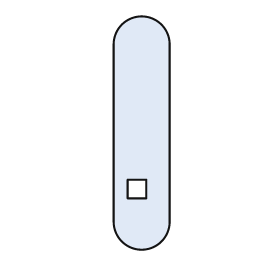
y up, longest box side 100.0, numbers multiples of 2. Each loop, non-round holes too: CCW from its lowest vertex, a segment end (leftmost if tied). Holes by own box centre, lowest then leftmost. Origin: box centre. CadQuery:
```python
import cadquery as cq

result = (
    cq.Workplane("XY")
    .moveTo(-12.0, -38.0)
    .threePointArc((0.0, -50.0), (12.0, -38.0))
    .lineTo(12.0, 38.0)
    .threePointArc((0.0, 50.0), (-12.0, 38.0))
    .close()
    .moveTo(-6.0, -28.0)
    .lineTo(2.0, -28.0)
    .lineTo(2.0, -20.0)
    .lineTo(-6.0, -20.0)
    .close()
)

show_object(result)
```